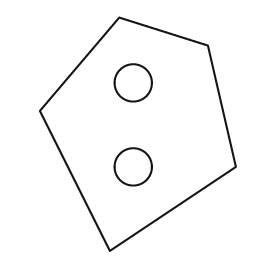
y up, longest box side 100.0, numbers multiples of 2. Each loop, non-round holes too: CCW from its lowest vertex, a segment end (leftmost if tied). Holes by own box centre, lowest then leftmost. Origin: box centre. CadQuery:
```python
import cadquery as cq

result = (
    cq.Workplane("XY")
    .moveTo(-12.0, -50.0)
    .lineTo(42.0, -14.0)
    .lineTo(30.0, 38.0)
    .lineTo(-8.0, 50.0)
    .lineTo(-42.0, 10.0)
    .close()
    .moveTo(-2.0, -14.0)
    .circle(8.0)
    .moveTo(-2.0, 22.0)
    .circle(8.0)
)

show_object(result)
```